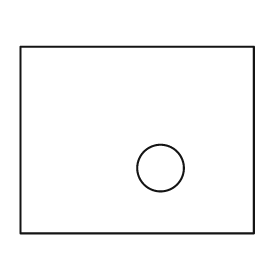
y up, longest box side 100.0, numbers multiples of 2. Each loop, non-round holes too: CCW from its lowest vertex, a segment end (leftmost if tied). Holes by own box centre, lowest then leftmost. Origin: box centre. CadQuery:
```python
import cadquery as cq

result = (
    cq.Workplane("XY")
    .moveTo(-50.0, -40.0)
    .lineTo(50.0, -40.0)
    .lineTo(50.0, 40.0)
    .lineTo(-50.0, 40.0)
    .close()
    .moveTo(10.0, -12.0)
    .circle(10.0)
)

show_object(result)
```